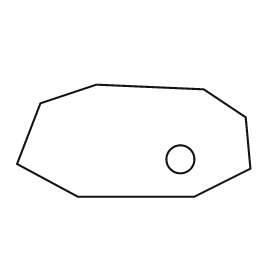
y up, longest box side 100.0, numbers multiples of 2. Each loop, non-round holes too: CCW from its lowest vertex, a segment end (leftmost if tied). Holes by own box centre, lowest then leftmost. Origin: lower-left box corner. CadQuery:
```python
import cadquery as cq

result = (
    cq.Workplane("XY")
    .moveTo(26.0, 0.0)
    .lineTo(76.0, 0.0)
    .lineTo(100.0, 12.0)
    .lineTo(98.0, 34.0)
    .lineTo(80.0, 46.0)
    .lineTo(34.0, 48.0)
    .lineTo(10.0, 40.0)
    .lineTo(0.0, 14.0)
    .close()
    .moveTo(70.0, 16.0)
    .circle(6.0)
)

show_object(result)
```